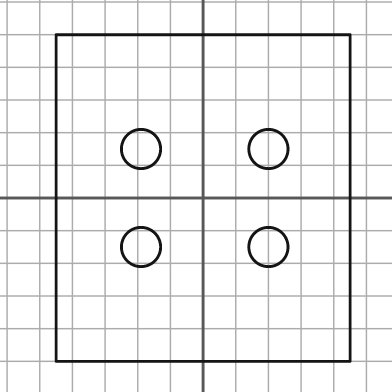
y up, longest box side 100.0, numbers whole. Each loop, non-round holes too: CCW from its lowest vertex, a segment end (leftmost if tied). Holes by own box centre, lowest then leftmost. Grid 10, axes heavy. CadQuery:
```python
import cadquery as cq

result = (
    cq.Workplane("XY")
    .moveTo(-45.0, -50.0)
    .lineTo(45.0, -50.0)
    .lineTo(45.0, 50.0)
    .lineTo(-45.0, 50.0)
    .close()
    .moveTo(-19.0, -15.0)
    .circle(6.0)
    .moveTo(20.0, -15.0)
    .circle(6.0)
    .moveTo(-19.0, 15.0)
    .circle(6.0)
    .moveTo(20.0, 15.0)
    .circle(6.0)
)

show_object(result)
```